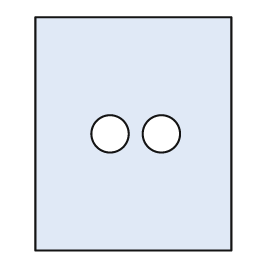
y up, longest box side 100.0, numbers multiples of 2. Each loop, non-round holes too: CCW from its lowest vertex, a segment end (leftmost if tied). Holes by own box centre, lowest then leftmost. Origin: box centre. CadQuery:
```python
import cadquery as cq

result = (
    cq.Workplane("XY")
    .moveTo(-42.0, -50.0)
    .lineTo(42.0, -50.0)
    .lineTo(42.0, 50.0)
    .lineTo(-42.0, 50.0)
    .close()
    .moveTo(-10.0, 0.0)
    .circle(8.0)
    .moveTo(12.0, 0.0)
    .circle(8.0)
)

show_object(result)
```